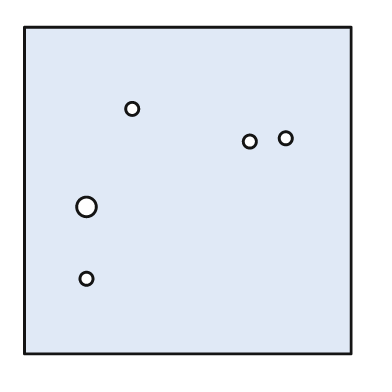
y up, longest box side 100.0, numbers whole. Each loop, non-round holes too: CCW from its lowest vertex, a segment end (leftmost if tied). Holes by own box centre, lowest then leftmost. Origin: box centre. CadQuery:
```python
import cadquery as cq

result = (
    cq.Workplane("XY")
    .moveTo(-50.0, -50.0)
    .lineTo(50.0, -50.0)
    .lineTo(50.0, 50.0)
    .lineTo(-50.0, 50.0)
    .close()
    .moveTo(-31.0, -27.0)
    .circle(2.0)
    .moveTo(-31.0, -5.0)
    .circle(3.0)
    .moveTo(19.0, 15.0)
    .circle(2.0)
    .moveTo(30.0, 16.0)
    .circle(2.0)
    .moveTo(-17.0, 25.0)
    .circle(2.0)
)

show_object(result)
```